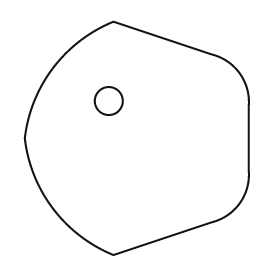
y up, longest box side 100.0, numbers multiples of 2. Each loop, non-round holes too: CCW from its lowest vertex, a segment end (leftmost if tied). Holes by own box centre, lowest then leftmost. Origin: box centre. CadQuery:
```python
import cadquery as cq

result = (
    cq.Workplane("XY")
    .moveTo(-10.0, -50.0)
    .lineTo(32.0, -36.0)
    .threePointArc((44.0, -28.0), (48.0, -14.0))
    .lineTo(48.0, 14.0)
    .threePointArc((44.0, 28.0), (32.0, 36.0))
    .lineTo(-10.0, 50.0)
    .threePointArc((-36.0, 30.0), (-48.0, 0.0))
    .threePointArc((-36.0, -30.0), (-10.0, -50.0))
    .close()
    .moveTo(-12.0, 16.0)
    .circle(6.0)
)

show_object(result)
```